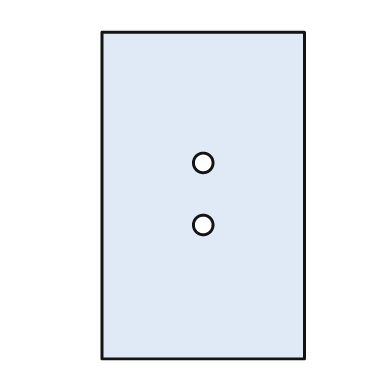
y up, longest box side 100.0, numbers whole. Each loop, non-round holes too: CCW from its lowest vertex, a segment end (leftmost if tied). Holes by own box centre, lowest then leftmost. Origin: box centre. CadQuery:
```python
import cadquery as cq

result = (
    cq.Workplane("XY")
    .moveTo(-31.0, -50.0)
    .lineTo(31.0, -50.0)
    .lineTo(31.0, 50.0)
    .lineTo(-31.0, 50.0)
    .close()
    .moveTo(0.0, -9.0)
    .circle(3.0)
    .moveTo(0.0, 10.0)
    .circle(3.0)
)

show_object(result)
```